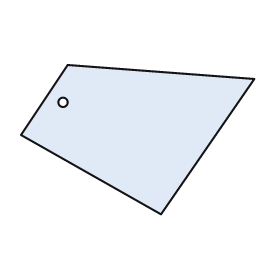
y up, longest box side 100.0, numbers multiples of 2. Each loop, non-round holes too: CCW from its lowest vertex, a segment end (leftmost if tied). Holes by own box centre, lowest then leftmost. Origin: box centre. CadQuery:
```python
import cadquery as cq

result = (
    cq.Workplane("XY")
    .moveTo(10.0, -32.0)
    .lineTo(50.0, 26.0)
    .lineTo(-30.0, 32.0)
    .lineTo(-50.0, 2.0)
    .close()
    .moveTo(-32.0, 16.0)
    .circle(2.0)
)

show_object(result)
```